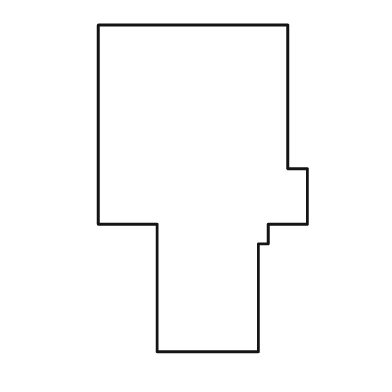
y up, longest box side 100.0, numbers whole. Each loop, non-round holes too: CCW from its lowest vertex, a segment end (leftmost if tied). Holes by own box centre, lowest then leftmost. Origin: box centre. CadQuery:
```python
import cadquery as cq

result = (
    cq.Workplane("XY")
    .moveTo(-14.0, -50.0)
    .lineTo(17.0, -50.0)
    .lineTo(17.0, -17.0)
    .lineTo(20.0, -17.0)
    .lineTo(20.0, -11.0)
    .lineTo(32.0, -11.0)
    .lineTo(32.0, 6.0)
    .lineTo(26.0, 6.0)
    .lineTo(26.0, 50.0)
    .lineTo(-32.0, 50.0)
    .lineTo(-32.0, -11.0)
    .lineTo(-14.0, -11.0)
    .close()
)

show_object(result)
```